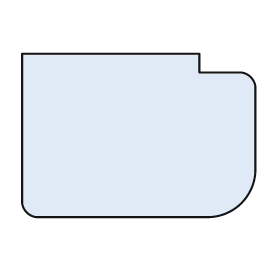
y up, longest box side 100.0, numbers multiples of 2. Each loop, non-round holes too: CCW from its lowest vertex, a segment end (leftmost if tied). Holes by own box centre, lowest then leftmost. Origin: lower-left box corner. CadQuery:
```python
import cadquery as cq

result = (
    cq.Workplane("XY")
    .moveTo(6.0, 0.0)
    .lineTo(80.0, 0.0)
    .threePointArc((94.0, 6.0), (100.0, 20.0))
    .lineTo(100.0, 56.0)
    .threePointArc((98.0, 60.0), (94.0, 62.0))
    .lineTo(76.0, 62.0)
    .lineTo(76.0, 70.0)
    .lineTo(0.0, 70.0)
    .lineTo(0.0, 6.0)
    .threePointArc((2.0, 2.0), (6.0, 0.0))
    .close()
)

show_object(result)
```